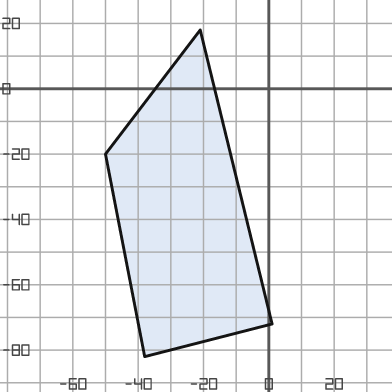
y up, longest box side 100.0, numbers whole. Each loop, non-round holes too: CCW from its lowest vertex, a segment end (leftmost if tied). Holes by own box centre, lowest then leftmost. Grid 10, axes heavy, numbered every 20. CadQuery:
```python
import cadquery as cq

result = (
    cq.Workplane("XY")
    .moveTo(-38.0, -82.0)
    .lineTo(1.0, -72.0)
    .lineTo(-21.0, 18.0)
    .lineTo(-50.0, -20.0)
    .close()
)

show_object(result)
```